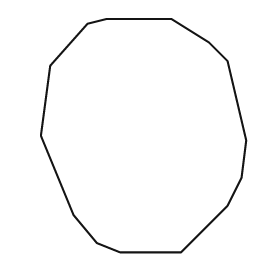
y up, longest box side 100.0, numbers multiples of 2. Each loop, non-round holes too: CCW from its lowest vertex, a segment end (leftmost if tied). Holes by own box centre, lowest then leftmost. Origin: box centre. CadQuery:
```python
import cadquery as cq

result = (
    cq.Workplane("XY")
    .moveTo(-10.0, -50.0)
    .lineTo(16.0, -50.0)
    .lineTo(36.0, -30.0)
    .lineTo(42.0, -18.0)
    .lineTo(44.0, -2.0)
    .lineTo(36.0, 32.0)
    .lineTo(28.0, 40.0)
    .lineTo(12.0, 50.0)
    .lineTo(-16.0, 50.0)
    .lineTo(-24.0, 48.0)
    .lineTo(-40.0, 30.0)
    .lineTo(-44.0, 0.0)
    .lineTo(-30.0, -34.0)
    .lineTo(-20.0, -46.0)
    .close()
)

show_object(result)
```